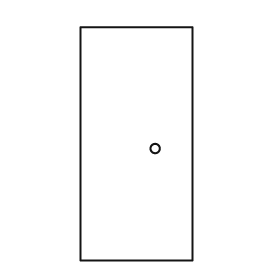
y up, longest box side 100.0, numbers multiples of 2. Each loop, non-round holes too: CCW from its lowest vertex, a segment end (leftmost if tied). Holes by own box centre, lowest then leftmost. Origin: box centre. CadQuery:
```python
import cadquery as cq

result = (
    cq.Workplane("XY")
    .moveTo(-24.0, -50.0)
    .lineTo(24.0, -50.0)
    .lineTo(24.0, 50.0)
    .lineTo(-24.0, 50.0)
    .close()
    .moveTo(8.0, -2.0)
    .circle(2.0)
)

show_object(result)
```